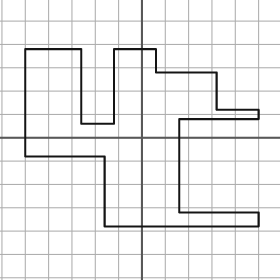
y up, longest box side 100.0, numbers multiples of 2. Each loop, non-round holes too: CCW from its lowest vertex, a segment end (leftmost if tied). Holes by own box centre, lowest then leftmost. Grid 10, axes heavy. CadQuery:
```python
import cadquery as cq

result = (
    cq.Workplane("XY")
    .moveTo(-16.0, -38.0)
    .lineTo(50.0, -38.0)
    .lineTo(50.0, -32.0)
    .lineTo(16.0, -32.0)
    .lineTo(16.0, 8.0)
    .lineTo(50.0, 8.0)
    .lineTo(50.0, 12.0)
    .lineTo(32.0, 12.0)
    .lineTo(32.0, 28.0)
    .lineTo(6.0, 28.0)
    .lineTo(6.0, 38.0)
    .lineTo(-12.0, 38.0)
    .lineTo(-12.0, 6.0)
    .lineTo(-26.0, 6.0)
    .lineTo(-26.0, 38.0)
    .lineTo(-50.0, 38.0)
    .lineTo(-50.0, -8.0)
    .lineTo(-16.0, -8.0)
    .close()
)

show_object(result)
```